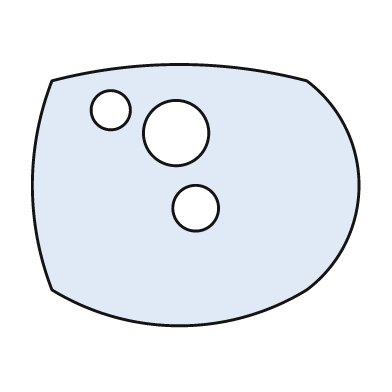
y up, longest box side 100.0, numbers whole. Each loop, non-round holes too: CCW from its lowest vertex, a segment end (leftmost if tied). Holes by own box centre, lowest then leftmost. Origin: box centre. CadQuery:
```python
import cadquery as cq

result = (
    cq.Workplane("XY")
    .moveTo(-44.0, -29.0)
    .threePointArc((-5.0, -40.0), (34.0, -29.0))
    .threePointArc((50.0, 3.0), (34.0, 35.0))
    .threePointArc((-5.0, 40.0), (-44.0, 35.0))
    .threePointArc((-50.0, 3.0), (-44.0, -29.0))
    .close()
    .moveTo(0.0, -4.0)
    .circle(7.0)
    .moveTo(-6.0, 19.0)
    .circle(10.0)
    .moveTo(-26.0, 26.0)
    .circle(6.0)
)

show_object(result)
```